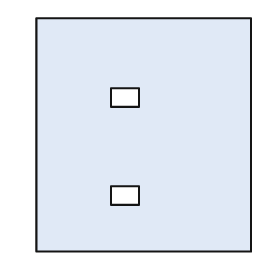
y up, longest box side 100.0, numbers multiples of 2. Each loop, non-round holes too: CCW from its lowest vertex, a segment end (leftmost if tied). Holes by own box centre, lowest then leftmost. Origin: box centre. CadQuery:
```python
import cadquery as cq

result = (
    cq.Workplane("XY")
    .moveTo(-46.0, -50.0)
    .lineTo(46.0, -50.0)
    .lineTo(46.0, 50.0)
    .lineTo(-46.0, 50.0)
    .close()
    .moveTo(-14.0, -30.0)
    .lineTo(-2.0, -30.0)
    .lineTo(-2.0, -22.0)
    .lineTo(-14.0, -22.0)
    .close()
    .moveTo(-14.0, 12.0)
    .lineTo(-2.0, 12.0)
    .lineTo(-2.0, 20.0)
    .lineTo(-14.0, 20.0)
    .close()
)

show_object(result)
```